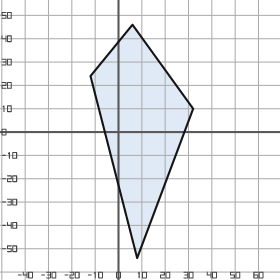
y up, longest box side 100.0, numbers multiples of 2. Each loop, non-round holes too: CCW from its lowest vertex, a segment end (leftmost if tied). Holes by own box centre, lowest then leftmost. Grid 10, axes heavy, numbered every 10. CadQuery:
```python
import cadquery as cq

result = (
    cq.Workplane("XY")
    .moveTo(8.0, -54.0)
    .lineTo(32.0, 10.0)
    .lineTo(6.0, 46.0)
    .lineTo(-12.0, 24.0)
    .close()
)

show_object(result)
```